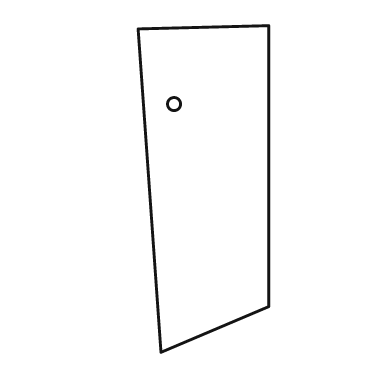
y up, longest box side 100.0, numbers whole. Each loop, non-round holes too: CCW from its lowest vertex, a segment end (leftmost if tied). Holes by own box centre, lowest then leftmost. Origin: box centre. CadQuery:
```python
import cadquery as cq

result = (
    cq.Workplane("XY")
    .moveTo(-13.0, -50.0)
    .lineTo(20.0, -36.0)
    .lineTo(20.0, 50.0)
    .lineTo(-20.0, 49.0)
    .close()
    .moveTo(-9.0, 26.0)
    .circle(2.0)
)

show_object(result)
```